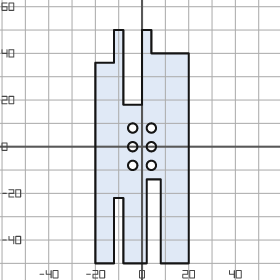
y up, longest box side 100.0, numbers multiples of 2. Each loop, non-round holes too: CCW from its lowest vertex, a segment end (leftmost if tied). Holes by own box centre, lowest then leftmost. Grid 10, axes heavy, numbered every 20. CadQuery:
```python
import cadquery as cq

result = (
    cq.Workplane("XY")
    .moveTo(-20.0, -50.0)
    .lineTo(-12.0, -50.0)
    .lineTo(-12.0, -22.0)
    .lineTo(-8.0, -22.0)
    .lineTo(-8.0, -50.0)
    .lineTo(2.0, -50.0)
    .lineTo(2.0, -14.0)
    .lineTo(8.0, -14.0)
    .lineTo(8.0, -50.0)
    .lineTo(20.0, -50.0)
    .lineTo(20.0, 40.0)
    .lineTo(4.0, 40.0)
    .lineTo(4.0, 50.0)
    .lineTo(0.0, 50.0)
    .lineTo(0.0, 18.0)
    .lineTo(-8.0, 18.0)
    .lineTo(-8.0, 50.0)
    .lineTo(-12.0, 50.0)
    .lineTo(-12.0, 36.0)
    .lineTo(-20.0, 36.0)
    .close()
    .moveTo(-4.0, -8.0)
    .circle(2.0)
    .moveTo(4.0, -8.0)
    .circle(2.0)
    .moveTo(-4.0, 0.0)
    .circle(2.0)
    .moveTo(4.0, 0.0)
    .circle(2.0)
    .moveTo(-4.0, 8.0)
    .circle(2.0)
    .moveTo(4.0, 8.0)
    .circle(2.0)
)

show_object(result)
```